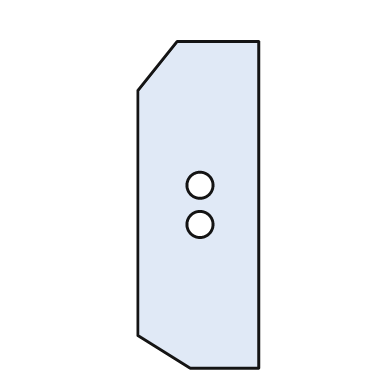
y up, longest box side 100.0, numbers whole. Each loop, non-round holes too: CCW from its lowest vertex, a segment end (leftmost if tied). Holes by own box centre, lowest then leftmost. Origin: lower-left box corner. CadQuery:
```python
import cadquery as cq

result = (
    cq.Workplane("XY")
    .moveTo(16.0, 0.0)
    .lineTo(37.0, 0.0)
    .lineTo(37.0, 100.0)
    .lineTo(12.0, 100.0)
    .lineTo(0.0, 85.0)
    .lineTo(0.0, 10.0)
    .close()
    .moveTo(19.0, 44.0)
    .circle(4.0)
    .moveTo(19.0, 56.0)
    .circle(4.0)
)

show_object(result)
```